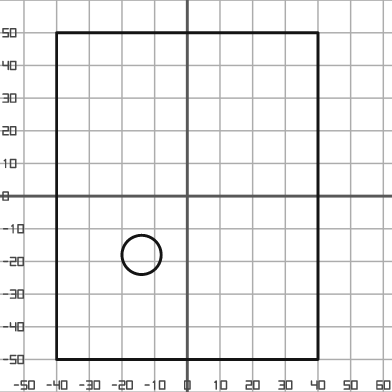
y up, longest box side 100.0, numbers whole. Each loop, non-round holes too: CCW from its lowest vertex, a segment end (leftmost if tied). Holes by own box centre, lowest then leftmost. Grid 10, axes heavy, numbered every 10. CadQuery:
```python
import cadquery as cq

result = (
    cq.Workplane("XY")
    .moveTo(-40.0, -50.0)
    .lineTo(40.0, -50.0)
    .lineTo(40.0, 50.0)
    .lineTo(-40.0, 50.0)
    .close()
    .moveTo(-14.0, -18.0)
    .circle(6.0)
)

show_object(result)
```